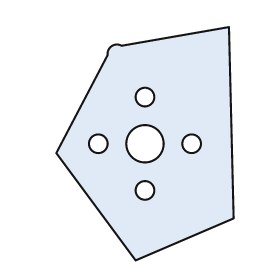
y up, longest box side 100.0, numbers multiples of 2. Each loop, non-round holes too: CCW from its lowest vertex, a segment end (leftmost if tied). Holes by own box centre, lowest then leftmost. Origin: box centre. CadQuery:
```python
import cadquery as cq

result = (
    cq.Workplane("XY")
    .moveTo(-4.0, -50.0)
    .lineTo(38.0, -32.0)
    .lineTo(36.0, 50.0)
    .lineTo(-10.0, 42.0)
    .threePointArc((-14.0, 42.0), (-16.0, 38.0))
    .lineTo(-38.0, -4.0)
    .close()
    .moveTo(0.0, -20.0)
    .circle(4.0)
    .moveTo(-20.0, 0.0)
    .circle(4.0)
    .moveTo(0.0, 0.0)
    .circle(8.0)
    .moveTo(20.0, 0.0)
    .circle(4.0)
    .moveTo(0.0, 20.0)
    .circle(4.0)
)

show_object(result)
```